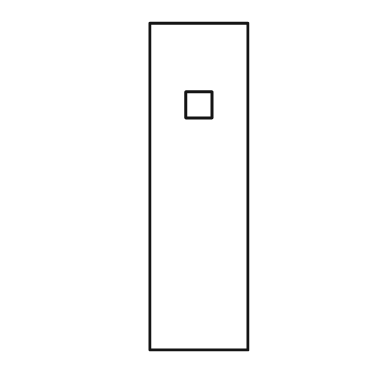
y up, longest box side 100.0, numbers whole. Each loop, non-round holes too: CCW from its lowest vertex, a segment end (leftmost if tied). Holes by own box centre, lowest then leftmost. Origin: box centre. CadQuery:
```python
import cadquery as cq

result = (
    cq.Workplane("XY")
    .moveTo(-15.0, -50.0)
    .lineTo(15.0, -50.0)
    .lineTo(15.0, 50.0)
    .lineTo(-15.0, 50.0)
    .close()
    .moveTo(-4.0, 21.0)
    .lineTo(4.0, 21.0)
    .lineTo(4.0, 29.0)
    .lineTo(-4.0, 29.0)
    .close()
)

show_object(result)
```